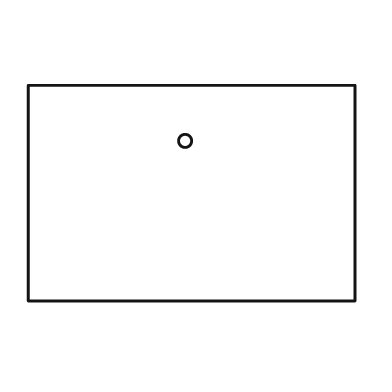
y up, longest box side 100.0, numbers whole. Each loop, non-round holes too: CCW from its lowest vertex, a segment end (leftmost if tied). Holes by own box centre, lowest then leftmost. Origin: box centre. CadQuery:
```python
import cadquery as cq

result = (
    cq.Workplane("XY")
    .moveTo(-50.0, -33.0)
    .lineTo(50.0, -33.0)
    .lineTo(50.0, 33.0)
    .lineTo(-50.0, 33.0)
    .close()
    .moveTo(-2.0, 16.0)
    .circle(2.0)
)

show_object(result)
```